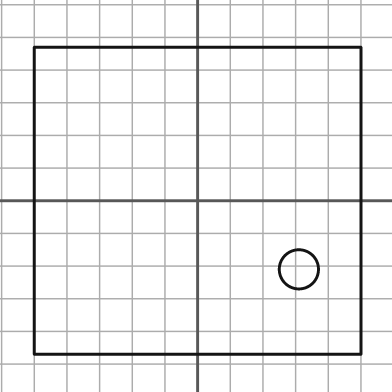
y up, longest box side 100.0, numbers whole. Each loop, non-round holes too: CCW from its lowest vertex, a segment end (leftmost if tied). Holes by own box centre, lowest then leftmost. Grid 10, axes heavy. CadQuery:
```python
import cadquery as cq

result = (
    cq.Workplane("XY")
    .moveTo(-50.0, -47.0)
    .lineTo(50.0, -47.0)
    .lineTo(50.0, 47.0)
    .lineTo(-50.0, 47.0)
    .close()
    .moveTo(31.0, -21.0)
    .circle(6.0)
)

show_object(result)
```